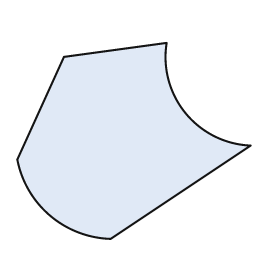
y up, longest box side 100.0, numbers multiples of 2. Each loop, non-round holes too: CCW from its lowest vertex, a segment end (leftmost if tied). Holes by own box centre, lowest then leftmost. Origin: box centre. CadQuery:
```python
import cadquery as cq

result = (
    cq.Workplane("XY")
    .moveTo(-10.0, -42.0)
    .lineTo(50.0, -2.0)
    .threePointArc((22.0, 12.0), (14.0, 42.0))
    .lineTo(-30.0, 36.0)
    .lineTo(-50.0, -8.0)
    .threePointArc((-36.0, -32.0), (-10.0, -42.0))
    .close()
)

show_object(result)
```